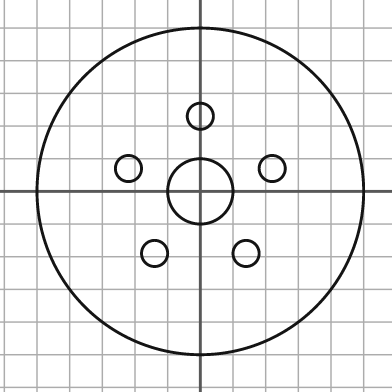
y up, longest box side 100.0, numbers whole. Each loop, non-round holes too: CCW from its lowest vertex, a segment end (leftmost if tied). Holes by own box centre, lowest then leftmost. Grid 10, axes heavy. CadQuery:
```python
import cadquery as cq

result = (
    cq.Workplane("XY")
    .moveTo(0.0, 0.0)
    .circle(50.0)
    .moveTo(-14.0, -19.0)
    .circle(4.0)
    .moveTo(14.0, -19.0)
    .circle(4.0)
    .moveTo(0.0, 0.0)
    .circle(10.0)
    .moveTo(-22.0, 7.0)
    .circle(4.0)
    .moveTo(22.0, 7.0)
    .circle(4.0)
    .moveTo(0.0, 23.0)
    .circle(4.0)
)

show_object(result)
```